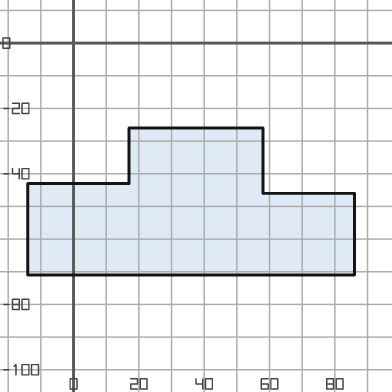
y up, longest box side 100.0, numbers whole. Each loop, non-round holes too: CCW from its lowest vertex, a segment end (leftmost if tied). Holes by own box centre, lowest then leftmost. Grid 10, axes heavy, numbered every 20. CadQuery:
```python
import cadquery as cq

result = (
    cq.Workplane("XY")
    .moveTo(-14.0, -71.0)
    .lineTo(86.0, -71.0)
    .lineTo(86.0, -46.0)
    .lineTo(58.0, -46.0)
    .lineTo(58.0, -26.0)
    .lineTo(17.0, -26.0)
    .lineTo(17.0, -43.0)
    .lineTo(-14.0, -43.0)
    .close()
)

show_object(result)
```